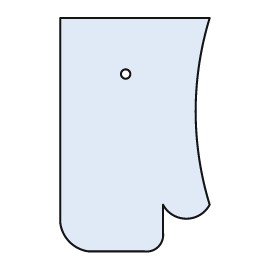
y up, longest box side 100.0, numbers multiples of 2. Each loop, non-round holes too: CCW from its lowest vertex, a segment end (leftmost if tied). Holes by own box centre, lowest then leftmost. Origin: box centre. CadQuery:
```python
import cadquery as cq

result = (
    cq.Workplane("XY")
    .moveTo(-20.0, -50.0)
    .lineTo(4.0, -50.0)
    .threePointArc((10.0, -48.0), (12.0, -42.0))
    .lineTo(12.0, -30.0)
    .threePointArc((22.0, -36.0), (32.0, -30.0))
    .threePointArc((26.0, 10.0), (32.0, 50.0))
    .lineTo(-32.0, 50.0)
    .lineTo(-32.0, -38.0)
    .threePointArc((-28.0, -46.0), (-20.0, -50.0))
    .close()
    .moveTo(-4.0, 26.0)
    .circle(2.0)
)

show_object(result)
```